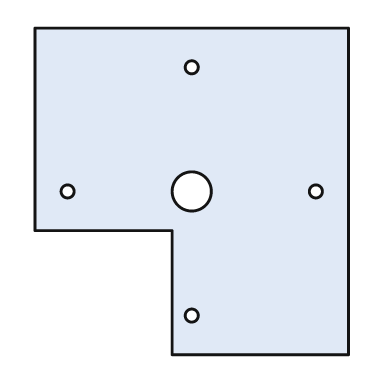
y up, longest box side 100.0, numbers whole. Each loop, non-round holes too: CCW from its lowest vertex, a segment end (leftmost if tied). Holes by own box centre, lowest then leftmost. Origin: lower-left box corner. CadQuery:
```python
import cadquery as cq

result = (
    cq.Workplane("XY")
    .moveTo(42.0, 0.0)
    .lineTo(96.0, 0.0)
    .lineTo(96.0, 100.0)
    .lineTo(0.0, 100.0)
    .lineTo(0.0, 38.0)
    .lineTo(42.0, 38.0)
    .close()
    .moveTo(48.0, 12.0)
    .circle(2.0)
    .moveTo(10.0, 50.0)
    .circle(2.0)
    .moveTo(48.0, 50.0)
    .circle(6.0)
    .moveTo(86.0, 50.0)
    .circle(2.0)
    .moveTo(48.0, 88.0)
    .circle(2.0)
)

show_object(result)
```